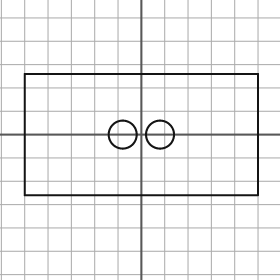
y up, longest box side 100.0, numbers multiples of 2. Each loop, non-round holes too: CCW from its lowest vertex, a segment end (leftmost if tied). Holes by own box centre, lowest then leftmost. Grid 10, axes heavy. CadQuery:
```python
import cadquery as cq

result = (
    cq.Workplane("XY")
    .moveTo(-50.0, -26.0)
    .lineTo(50.0, -26.0)
    .lineTo(50.0, 26.0)
    .lineTo(-50.0, 26.0)
    .close()
    .moveTo(-8.0, 0.0)
    .circle(6.0)
    .moveTo(8.0, 0.0)
    .circle(6.0)
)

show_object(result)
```